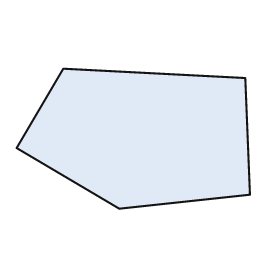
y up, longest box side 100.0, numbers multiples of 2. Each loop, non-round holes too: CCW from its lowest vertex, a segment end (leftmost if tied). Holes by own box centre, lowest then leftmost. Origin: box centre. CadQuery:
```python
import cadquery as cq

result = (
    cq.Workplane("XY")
    .moveTo(-6.0, -30.0)
    .lineTo(50.0, -24.0)
    .lineTo(48.0, 26.0)
    .lineTo(-30.0, 30.0)
    .lineTo(-50.0, -4.0)
    .close()
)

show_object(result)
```